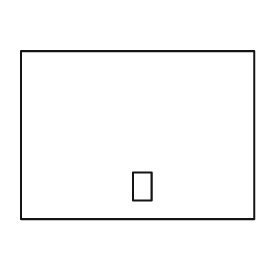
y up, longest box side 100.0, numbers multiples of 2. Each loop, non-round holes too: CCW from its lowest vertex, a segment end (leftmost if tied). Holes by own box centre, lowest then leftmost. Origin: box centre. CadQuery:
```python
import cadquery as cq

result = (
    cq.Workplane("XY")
    .moveTo(-50.0, -36.0)
    .lineTo(50.0, -36.0)
    .lineTo(50.0, 36.0)
    .lineTo(-50.0, 36.0)
    .close()
    .moveTo(-2.0, -28.0)
    .lineTo(6.0, -28.0)
    .lineTo(6.0, -16.0)
    .lineTo(-2.0, -16.0)
    .close()
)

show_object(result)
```